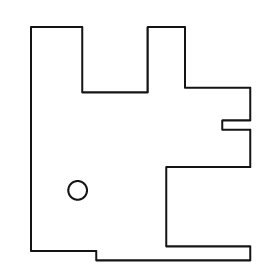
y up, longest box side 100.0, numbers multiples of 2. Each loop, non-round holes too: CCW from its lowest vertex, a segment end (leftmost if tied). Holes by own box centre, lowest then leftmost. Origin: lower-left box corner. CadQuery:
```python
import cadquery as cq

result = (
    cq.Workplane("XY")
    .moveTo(28.0, 0.0)
    .lineTo(94.0, 0.0)
    .lineTo(94.0, 6.0)
    .lineTo(58.0, 6.0)
    .lineTo(58.0, 40.0)
    .lineTo(94.0, 40.0)
    .lineTo(94.0, 56.0)
    .lineTo(82.0, 56.0)
    .lineTo(82.0, 60.0)
    .lineTo(94.0, 60.0)
    .lineTo(94.0, 74.0)
    .lineTo(66.0, 74.0)
    .lineTo(66.0, 100.0)
    .lineTo(50.0, 100.0)
    .lineTo(50.0, 72.0)
    .lineTo(22.0, 72.0)
    .lineTo(22.0, 100.0)
    .lineTo(0.0, 100.0)
    .lineTo(0.0, 4.0)
    .lineTo(28.0, 4.0)
    .close()
    .moveTo(20.0, 30.0)
    .circle(4.0)
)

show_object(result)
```